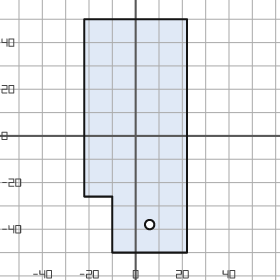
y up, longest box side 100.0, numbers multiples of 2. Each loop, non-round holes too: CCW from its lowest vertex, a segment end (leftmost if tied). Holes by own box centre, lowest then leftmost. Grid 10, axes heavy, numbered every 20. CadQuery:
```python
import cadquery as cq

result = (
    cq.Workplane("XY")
    .moveTo(-10.0, -50.0)
    .lineTo(22.0, -50.0)
    .lineTo(22.0, 50.0)
    .lineTo(-22.0, 50.0)
    .lineTo(-22.0, -26.0)
    .lineTo(-10.0, -26.0)
    .close()
    .moveTo(6.0, -38.0)
    .circle(2.0)
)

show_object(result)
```